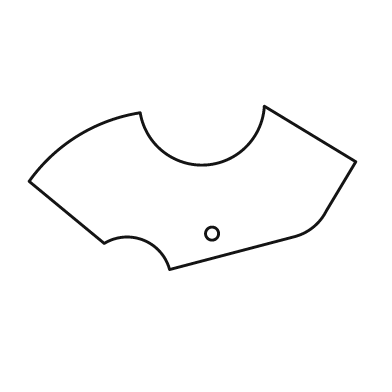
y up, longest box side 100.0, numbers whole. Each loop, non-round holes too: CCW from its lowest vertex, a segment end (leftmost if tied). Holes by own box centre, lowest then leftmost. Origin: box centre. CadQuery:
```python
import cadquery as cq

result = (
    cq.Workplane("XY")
    .moveTo(-7.0, -25.0)
    .lineTo(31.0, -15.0)
    .threePointArc((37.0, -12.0), (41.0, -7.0))
    .lineTo(50.0, 8.0)
    .lineTo(22.0, 25.0)
    .threePointArc((4.0, 7.0), (-16.0, 23.0))
    .threePointArc((-35.0, 16.0), (-50.0, 2.0))
    .lineTo(-27.0, -17.0)
    .threePointArc((-15.0, -16.0), (-7.0, -25.0))
    .close()
    .moveTo(6.0, -14.0)
    .circle(2.0)
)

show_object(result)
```